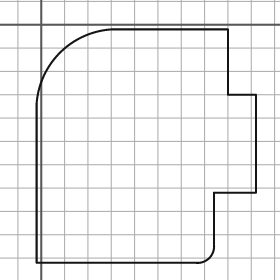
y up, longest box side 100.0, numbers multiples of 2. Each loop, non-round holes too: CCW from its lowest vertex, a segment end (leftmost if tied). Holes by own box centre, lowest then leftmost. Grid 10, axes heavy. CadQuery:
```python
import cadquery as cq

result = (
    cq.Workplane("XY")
    .moveTo(-2.0, -102.0)
    .lineTo(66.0, -102.0)
    .threePointArc((72.0, -100.0), (74.0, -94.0))
    .lineTo(74.0, -72.0)
    .lineTo(92.0, -72.0)
    .lineTo(92.0, -30.0)
    .lineTo(80.0, -30.0)
    .lineTo(80.0, -2.0)
    .lineTo(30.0, -2.0)
    .threePointArc((8.0, -12.0), (-2.0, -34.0))
    .close()
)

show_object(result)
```